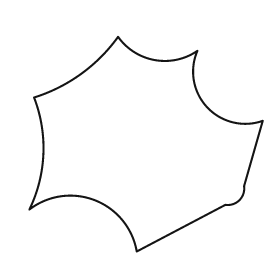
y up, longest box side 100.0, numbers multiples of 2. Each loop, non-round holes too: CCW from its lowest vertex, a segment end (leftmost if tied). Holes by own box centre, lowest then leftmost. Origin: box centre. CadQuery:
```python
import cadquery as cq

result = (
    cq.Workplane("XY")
    .moveTo(-4.0, -46.0)
    .lineTo(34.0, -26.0)
    .threePointArc((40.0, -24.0), (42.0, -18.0))
    .lineTo(50.0, 10.0)
    .threePointArc((26.0, 16.0), (22.0, 40.0))
    .threePointArc((4.0, 36.0), (-12.0, 46.0))
    .threePointArc((-28.0, 30.0), (-48.0, 20.0))
    .threePointArc((-44.0, -4.0), (-50.0, -28.0))
    .threePointArc((-22.0, -24.0), (-4.0, -46.0))
    .close()
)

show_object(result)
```